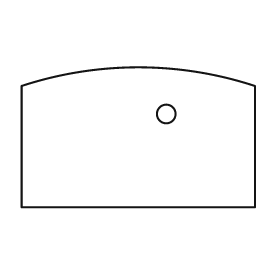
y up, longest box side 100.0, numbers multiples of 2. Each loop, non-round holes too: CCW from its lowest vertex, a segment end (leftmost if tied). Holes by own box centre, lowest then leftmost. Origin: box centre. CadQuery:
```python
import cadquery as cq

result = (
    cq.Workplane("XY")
    .moveTo(-50.0, -30.0)
    .lineTo(50.0, -30.0)
    .lineTo(50.0, 22.0)
    .threePointArc((0.0, 30.0), (-50.0, 22.0))
    .close()
    .moveTo(12.0, 10.0)
    .circle(4.0)
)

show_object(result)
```